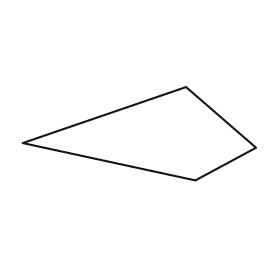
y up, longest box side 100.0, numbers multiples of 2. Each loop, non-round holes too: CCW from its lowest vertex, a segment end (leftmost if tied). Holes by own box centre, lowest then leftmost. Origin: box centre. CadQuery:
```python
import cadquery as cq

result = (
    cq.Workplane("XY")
    .moveTo(24.0, -20.0)
    .lineTo(50.0, -6.0)
    .lineTo(20.0, 20.0)
    .lineTo(-50.0, -4.0)
    .close()
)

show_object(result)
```